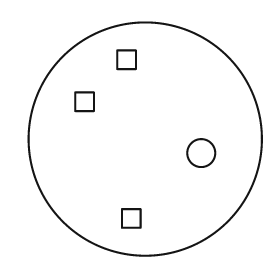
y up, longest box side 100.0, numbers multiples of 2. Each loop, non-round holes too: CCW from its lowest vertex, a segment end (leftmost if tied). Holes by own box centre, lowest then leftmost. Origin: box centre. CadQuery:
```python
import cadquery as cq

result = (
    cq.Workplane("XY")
    .moveTo(0.0, 0.0)
    .circle(50.0)
    .moveTo(-10.0, -38.0)
    .lineTo(-2.0, -38.0)
    .lineTo(-2.0, -30.0)
    .lineTo(-10.0, -30.0)
    .close()
    .moveTo(24.0, -6.0)
    .circle(6.0)
    .moveTo(-30.0, 12.0)
    .lineTo(-22.0, 12.0)
    .lineTo(-22.0, 20.0)
    .lineTo(-30.0, 20.0)
    .close()
    .moveTo(-12.0, 30.0)
    .lineTo(-4.0, 30.0)
    .lineTo(-4.0, 38.0)
    .lineTo(-12.0, 38.0)
    .close()
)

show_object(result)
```